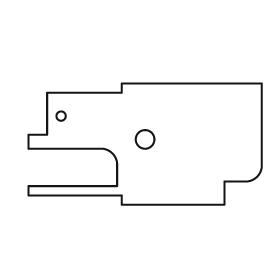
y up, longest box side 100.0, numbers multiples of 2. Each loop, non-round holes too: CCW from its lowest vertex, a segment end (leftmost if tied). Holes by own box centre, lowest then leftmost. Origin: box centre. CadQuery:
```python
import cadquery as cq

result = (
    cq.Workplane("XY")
    .moveTo(-10.0, -26.0)
    .lineTo(34.0, -26.0)
    .lineTo(34.0, -16.0)
    .lineTo(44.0, -16.0)
    .threePointArc((48.0, -14.0), (50.0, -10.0))
    .lineTo(50.0, 26.0)
    .lineTo(-10.0, 26.0)
    .lineTo(-10.0, 22.0)
    .lineTo(-42.0, 22.0)
    .lineTo(-42.0, 4.0)
    .lineTo(-50.0, 4.0)
    .lineTo(-50.0, -2.0)
    .lineTo(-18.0, -2.0)
    .threePointArc((-14.0, -4.0), (-12.0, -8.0))
    .lineTo(-12.0, -18.0)
    .lineTo(-50.0, -18.0)
    .lineTo(-50.0, -22.0)
    .lineTo(-10.0, -22.0)
    .close()
    .moveTo(0.0, 2.0)
    .circle(4.0)
    .moveTo(-36.0, 12.0)
    .circle(2.0)
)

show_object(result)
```